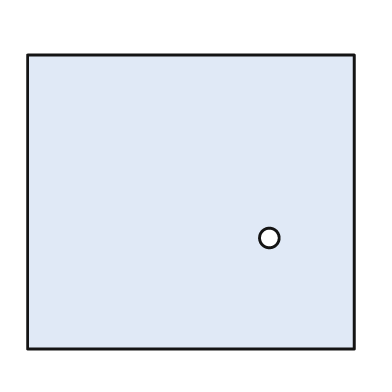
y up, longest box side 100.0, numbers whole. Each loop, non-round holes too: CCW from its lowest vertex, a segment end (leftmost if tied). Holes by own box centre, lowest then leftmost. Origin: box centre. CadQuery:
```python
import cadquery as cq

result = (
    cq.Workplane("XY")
    .moveTo(-50.0, -45.0)
    .lineTo(50.0, -45.0)
    .lineTo(50.0, 45.0)
    .lineTo(-50.0, 45.0)
    .close()
    .moveTo(24.0, -11.0)
    .circle(3.0)
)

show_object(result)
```